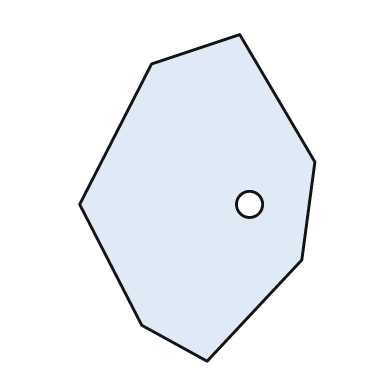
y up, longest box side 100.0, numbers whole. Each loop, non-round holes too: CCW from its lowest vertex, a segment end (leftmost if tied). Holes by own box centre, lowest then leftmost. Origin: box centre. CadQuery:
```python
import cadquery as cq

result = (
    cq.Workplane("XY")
    .moveTo(3.0, -50.0)
    .lineTo(32.0, -19.0)
    .lineTo(36.0, 11.0)
    .lineTo(13.0, 50.0)
    .lineTo(-14.0, 41.0)
    .lineTo(-36.0, -2.0)
    .lineTo(-17.0, -39.0)
    .close()
    .moveTo(16.0, -2.0)
    .circle(4.0)
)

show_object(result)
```